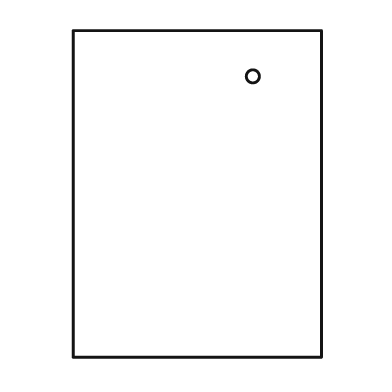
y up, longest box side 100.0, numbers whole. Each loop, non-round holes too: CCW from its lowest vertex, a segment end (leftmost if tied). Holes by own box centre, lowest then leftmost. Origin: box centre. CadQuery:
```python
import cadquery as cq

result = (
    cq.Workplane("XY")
    .moveTo(-38.0, -50.0)
    .lineTo(38.0, -50.0)
    .lineTo(38.0, 50.0)
    .lineTo(-38.0, 50.0)
    .close()
    .moveTo(17.0, 36.0)
    .circle(2.0)
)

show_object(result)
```